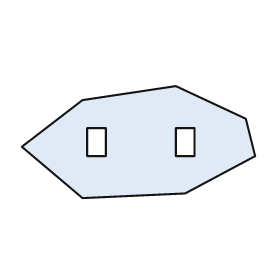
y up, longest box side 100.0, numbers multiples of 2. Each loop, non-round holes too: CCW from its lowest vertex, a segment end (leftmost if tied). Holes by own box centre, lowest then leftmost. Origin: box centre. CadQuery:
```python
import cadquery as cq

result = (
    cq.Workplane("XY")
    .moveTo(-24.0, -24.0)
    .lineTo(20.0, -22.0)
    .lineTo(50.0, -6.0)
    .lineTo(46.0, 10.0)
    .lineTo(16.0, 24.0)
    .lineTo(-24.0, 18.0)
    .lineTo(-50.0, -2.0)
    .close()
    .moveTo(-22.0, -6.0)
    .lineTo(-14.0, -6.0)
    .lineTo(-14.0, 6.0)
    .lineTo(-22.0, 6.0)
    .close()
    .moveTo(16.0, -6.0)
    .lineTo(24.0, -6.0)
    .lineTo(24.0, 6.0)
    .lineTo(16.0, 6.0)
    .close()
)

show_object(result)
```